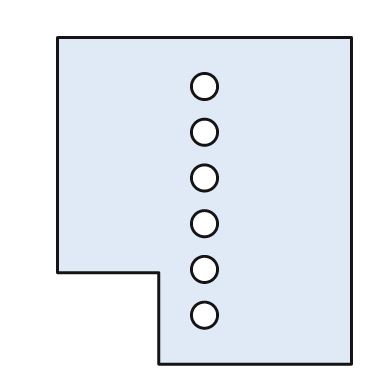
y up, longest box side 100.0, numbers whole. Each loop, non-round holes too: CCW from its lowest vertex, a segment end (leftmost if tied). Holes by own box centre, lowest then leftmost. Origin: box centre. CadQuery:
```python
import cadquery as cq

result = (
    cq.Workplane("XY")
    .moveTo(-14.0, -50.0)
    .lineTo(45.0, -50.0)
    .lineTo(45.0, 50.0)
    .lineTo(-45.0, 50.0)
    .lineTo(-45.0, -22.0)
    .lineTo(-14.0, -22.0)
    .close()
    .moveTo(0.0, -35.0)
    .circle(4.0)
    .moveTo(0.0, -21.0)
    .circle(4.0)
    .moveTo(0.0, -7.0)
    .circle(4.0)
    .moveTo(0.0, 7.0)
    .circle(4.0)
    .moveTo(0.0, 21.0)
    .circle(4.0)
    .moveTo(0.0, 35.0)
    .circle(4.0)
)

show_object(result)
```